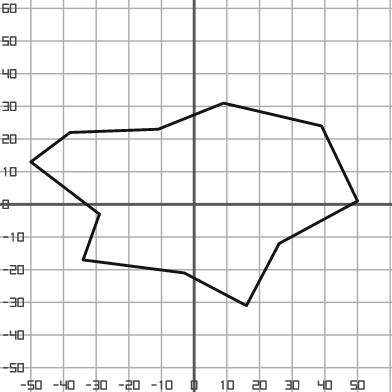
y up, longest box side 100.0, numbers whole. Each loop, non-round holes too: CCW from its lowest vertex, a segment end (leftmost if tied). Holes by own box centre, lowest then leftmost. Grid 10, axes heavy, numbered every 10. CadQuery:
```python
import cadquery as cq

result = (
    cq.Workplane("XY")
    .moveTo(16.0, -31.0)
    .lineTo(26.0, -12.0)
    .lineTo(50.0, 1.0)
    .lineTo(39.0, 24.0)
    .lineTo(9.0, 31.0)
    .lineTo(-11.0, 23.0)
    .lineTo(-38.0, 22.0)
    .lineTo(-50.0, 13.0)
    .lineTo(-29.0, -3.0)
    .lineTo(-34.0, -17.0)
    .lineTo(-3.0, -21.0)
    .close()
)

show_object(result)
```